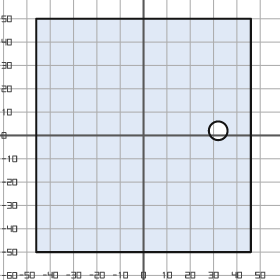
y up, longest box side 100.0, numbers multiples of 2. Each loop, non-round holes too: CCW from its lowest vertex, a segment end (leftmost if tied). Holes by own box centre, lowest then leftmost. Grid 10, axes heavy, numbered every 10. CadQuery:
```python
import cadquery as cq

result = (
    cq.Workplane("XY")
    .moveTo(-46.0, -50.0)
    .lineTo(46.0, -50.0)
    .lineTo(46.0, 50.0)
    .lineTo(-46.0, 50.0)
    .close()
    .moveTo(32.0, 2.0)
    .circle(4.0)
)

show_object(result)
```